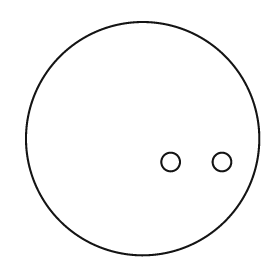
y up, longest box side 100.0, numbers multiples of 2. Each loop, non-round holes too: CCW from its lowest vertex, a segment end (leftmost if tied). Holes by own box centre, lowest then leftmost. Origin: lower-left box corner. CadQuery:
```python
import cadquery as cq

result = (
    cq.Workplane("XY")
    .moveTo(50.0, 50.0)
    .circle(50.0)
    .moveTo(62.0, 40.0)
    .circle(4.0)
    .moveTo(84.0, 40.0)
    .circle(4.0)
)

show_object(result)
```